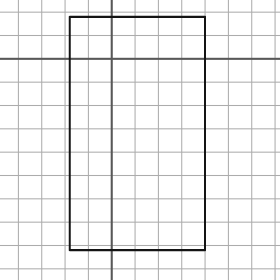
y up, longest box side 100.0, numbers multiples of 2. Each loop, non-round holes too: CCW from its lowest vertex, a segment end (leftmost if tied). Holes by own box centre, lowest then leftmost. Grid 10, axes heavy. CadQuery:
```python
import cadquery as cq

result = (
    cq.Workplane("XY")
    .moveTo(-18.0, -82.0)
    .lineTo(40.0, -82.0)
    .lineTo(40.0, 18.0)
    .lineTo(-18.0, 18.0)
    .close()
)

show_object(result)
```